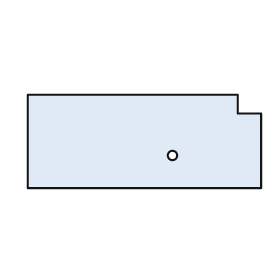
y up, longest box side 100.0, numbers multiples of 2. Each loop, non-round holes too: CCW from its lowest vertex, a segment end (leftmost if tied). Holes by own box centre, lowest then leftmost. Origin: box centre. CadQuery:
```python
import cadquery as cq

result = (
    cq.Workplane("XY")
    .moveTo(-50.0, -20.0)
    .lineTo(50.0, -20.0)
    .lineTo(50.0, 12.0)
    .lineTo(40.0, 12.0)
    .lineTo(40.0, 20.0)
    .lineTo(-50.0, 20.0)
    .close()
    .moveTo(12.0, -6.0)
    .circle(2.0)
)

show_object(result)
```